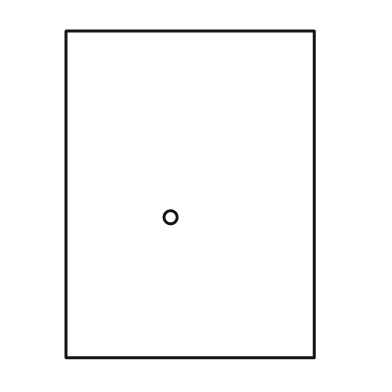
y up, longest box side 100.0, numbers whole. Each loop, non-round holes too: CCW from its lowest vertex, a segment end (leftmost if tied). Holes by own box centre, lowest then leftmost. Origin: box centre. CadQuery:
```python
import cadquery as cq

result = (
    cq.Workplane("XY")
    .moveTo(-38.0, -50.0)
    .lineTo(38.0, -50.0)
    .lineTo(38.0, 50.0)
    .lineTo(-38.0, 50.0)
    .close()
    .moveTo(-6.0, -7.0)
    .circle(2.0)
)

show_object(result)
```